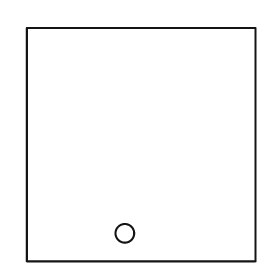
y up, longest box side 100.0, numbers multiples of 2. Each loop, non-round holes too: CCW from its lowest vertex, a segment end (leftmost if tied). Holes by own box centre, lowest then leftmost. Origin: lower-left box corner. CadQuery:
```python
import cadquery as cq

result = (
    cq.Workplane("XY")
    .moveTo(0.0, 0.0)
    .lineTo(98.0, 0.0)
    .lineTo(98.0, 100.0)
    .lineTo(0.0, 100.0)
    .close()
    .moveTo(42.0, 12.0)
    .circle(4.0)
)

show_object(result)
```